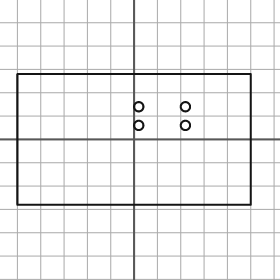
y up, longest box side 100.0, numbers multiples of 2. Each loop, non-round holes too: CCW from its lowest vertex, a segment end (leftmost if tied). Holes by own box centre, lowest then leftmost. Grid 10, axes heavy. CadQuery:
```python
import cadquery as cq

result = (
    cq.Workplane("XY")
    .moveTo(-50.0, -28.0)
    .lineTo(50.0, -28.0)
    .lineTo(50.0, 28.0)
    .lineTo(-50.0, 28.0)
    .close()
    .moveTo(2.0, 6.0)
    .circle(2.0)
    .moveTo(22.0, 6.0)
    .circle(2.0)
    .moveTo(2.0, 14.0)
    .circle(2.0)
    .moveTo(22.0, 14.0)
    .circle(2.0)
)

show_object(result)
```